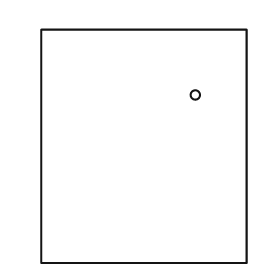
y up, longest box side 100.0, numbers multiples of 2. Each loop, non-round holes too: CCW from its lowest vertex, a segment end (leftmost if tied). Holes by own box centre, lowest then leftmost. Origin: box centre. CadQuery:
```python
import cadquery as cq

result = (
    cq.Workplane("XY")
    .moveTo(-44.0, -50.0)
    .lineTo(44.0, -50.0)
    .lineTo(44.0, 50.0)
    .lineTo(-44.0, 50.0)
    .close()
    .moveTo(22.0, 22.0)
    .circle(2.0)
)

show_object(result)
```